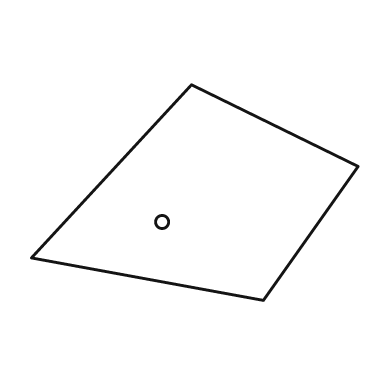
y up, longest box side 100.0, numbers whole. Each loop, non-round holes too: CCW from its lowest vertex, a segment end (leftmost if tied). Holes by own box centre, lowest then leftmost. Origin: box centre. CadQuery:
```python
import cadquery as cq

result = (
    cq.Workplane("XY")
    .moveTo(21.0, -33.0)
    .lineTo(50.0, 8.0)
    .lineTo(-1.0, 33.0)
    .lineTo(-50.0, -20.0)
    .close()
    .moveTo(-10.0, -9.0)
    .circle(2.0)
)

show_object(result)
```